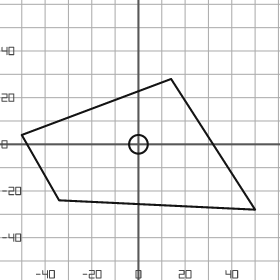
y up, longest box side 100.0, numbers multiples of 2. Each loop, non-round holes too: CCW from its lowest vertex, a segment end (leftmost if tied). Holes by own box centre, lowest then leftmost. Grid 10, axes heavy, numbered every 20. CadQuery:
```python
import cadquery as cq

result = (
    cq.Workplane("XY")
    .moveTo(50.0, -28.0)
    .lineTo(14.0, 28.0)
    .lineTo(-50.0, 4.0)
    .lineTo(-34.0, -24.0)
    .close()
    .moveTo(0.0, 0.0)
    .circle(4.0)
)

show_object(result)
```